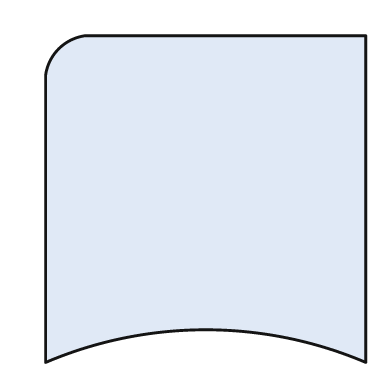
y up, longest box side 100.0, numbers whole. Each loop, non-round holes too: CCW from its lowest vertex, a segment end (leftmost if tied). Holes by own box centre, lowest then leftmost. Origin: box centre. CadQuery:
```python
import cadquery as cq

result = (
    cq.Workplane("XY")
    .moveTo(-49.0, -50.0)
    .threePointArc((0.0, -40.0), (49.0, -50.0))
    .lineTo(49.0, 50.0)
    .lineTo(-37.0, 50.0)
    .threePointArc((-45.0, 46.0), (-49.0, 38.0))
    .close()
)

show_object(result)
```